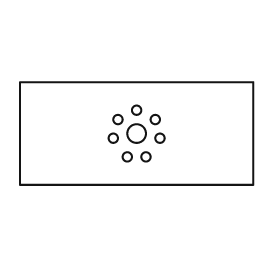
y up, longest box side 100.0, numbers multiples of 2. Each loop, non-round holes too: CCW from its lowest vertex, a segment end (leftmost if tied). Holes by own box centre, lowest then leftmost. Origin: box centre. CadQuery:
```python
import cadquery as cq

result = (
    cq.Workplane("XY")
    .moveTo(-50.0, -22.0)
    .lineTo(50.0, -22.0)
    .lineTo(50.0, 22.0)
    .lineTo(-50.0, 22.0)
    .close()
    .moveTo(-4.0, -10.0)
    .circle(2.0)
    .moveTo(4.0, -10.0)
    .circle(2.0)
    .moveTo(-10.0, -2.0)
    .circle(2.0)
    .moveTo(10.0, -2.0)
    .circle(2.0)
    .moveTo(0.0, 0.0)
    .circle(4.0)
    .moveTo(-8.0, 6.0)
    .circle(2.0)
    .moveTo(8.0, 6.0)
    .circle(2.0)
    .moveTo(0.0, 10.0)
    .circle(2.0)
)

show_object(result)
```